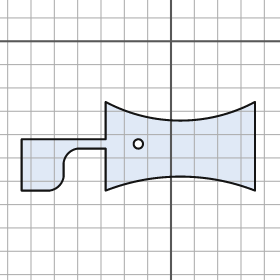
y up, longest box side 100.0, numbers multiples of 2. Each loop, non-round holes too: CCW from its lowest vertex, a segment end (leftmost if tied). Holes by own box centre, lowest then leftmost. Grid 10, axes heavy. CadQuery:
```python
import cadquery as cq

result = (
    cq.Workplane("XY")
    .moveTo(-64.0, -64.0)
    .lineTo(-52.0, -64.0)
    .threePointArc((-48.0, -62.0), (-46.0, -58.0))
    .lineTo(-46.0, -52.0)
    .threePointArc((-44.0, -48.0), (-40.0, -46.0))
    .lineTo(-28.0, -46.0)
    .lineTo(-28.0, -64.0)
    .threePointArc((4.0, -58.0), (36.0, -64.0))
    .lineTo(36.0, -26.0)
    .threePointArc((4.0, -34.0), (-28.0, -26.0))
    .lineTo(-28.0, -42.0)
    .lineTo(-64.0, -42.0)
    .close()
    .moveTo(-14.0, -44.0)
    .circle(2.0)
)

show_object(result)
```